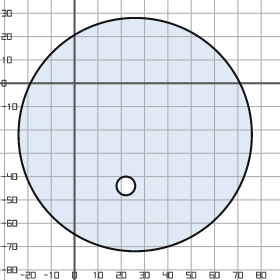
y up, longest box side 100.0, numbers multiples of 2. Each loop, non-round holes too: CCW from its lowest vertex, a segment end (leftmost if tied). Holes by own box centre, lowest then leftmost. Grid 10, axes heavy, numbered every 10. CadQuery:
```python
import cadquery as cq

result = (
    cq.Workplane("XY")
    .moveTo(26.0, -22.0)
    .circle(50.0)
    .moveTo(22.0, -44.0)
    .circle(4.0)
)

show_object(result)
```